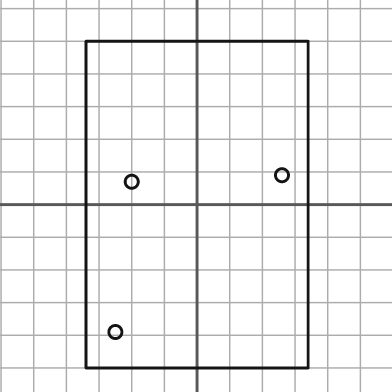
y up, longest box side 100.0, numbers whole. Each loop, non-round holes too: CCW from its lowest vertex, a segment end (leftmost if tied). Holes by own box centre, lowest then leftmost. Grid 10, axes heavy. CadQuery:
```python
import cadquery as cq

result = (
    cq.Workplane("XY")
    .moveTo(-34.0, -50.0)
    .lineTo(34.0, -50.0)
    .lineTo(34.0, 50.0)
    .lineTo(-34.0, 50.0)
    .close()
    .moveTo(-25.0, -39.0)
    .circle(2.0)
    .moveTo(-20.0, 7.0)
    .circle(2.0)
    .moveTo(26.0, 9.0)
    .circle(2.0)
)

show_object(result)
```